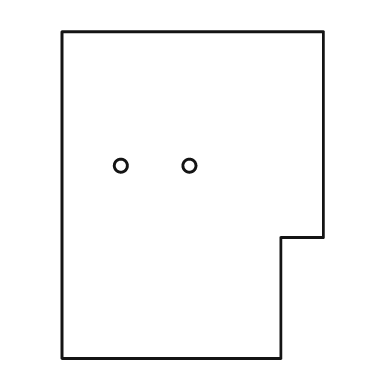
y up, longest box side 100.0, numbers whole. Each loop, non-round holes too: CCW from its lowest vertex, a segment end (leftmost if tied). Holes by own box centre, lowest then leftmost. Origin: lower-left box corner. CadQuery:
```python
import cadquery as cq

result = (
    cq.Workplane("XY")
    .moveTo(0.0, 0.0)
    .lineTo(67.0, 0.0)
    .lineTo(67.0, 37.0)
    .lineTo(80.0, 37.0)
    .lineTo(80.0, 100.0)
    .lineTo(0.0, 100.0)
    .close()
    .moveTo(18.0, 59.0)
    .circle(2.0)
    .moveTo(39.0, 59.0)
    .circle(2.0)
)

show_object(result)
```